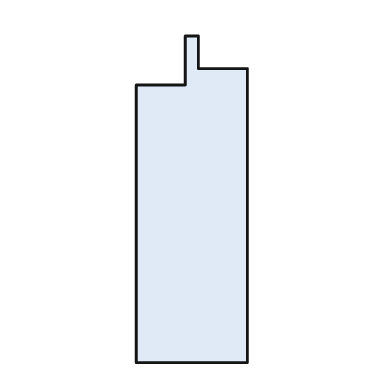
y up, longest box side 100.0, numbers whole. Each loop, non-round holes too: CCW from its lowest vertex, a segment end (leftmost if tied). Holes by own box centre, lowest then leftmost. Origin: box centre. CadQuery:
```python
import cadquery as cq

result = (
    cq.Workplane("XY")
    .moveTo(-17.0, -50.0)
    .lineTo(17.0, -50.0)
    .lineTo(17.0, 40.0)
    .lineTo(2.0, 40.0)
    .lineTo(2.0, 50.0)
    .lineTo(-2.0, 50.0)
    .lineTo(-2.0, 35.0)
    .lineTo(-17.0, 35.0)
    .close()
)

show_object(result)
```